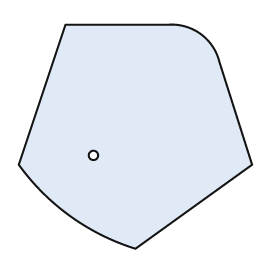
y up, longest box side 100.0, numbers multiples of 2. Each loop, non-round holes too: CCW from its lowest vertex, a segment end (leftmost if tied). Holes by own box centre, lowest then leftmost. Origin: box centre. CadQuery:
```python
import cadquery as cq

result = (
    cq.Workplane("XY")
    .moveTo(0.0, -48.0)
    .lineTo(50.0, -12.0)
    .lineTo(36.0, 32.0)
    .threePointArc((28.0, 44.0), (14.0, 48.0))
    .lineTo(-30.0, 48.0)
    .lineTo(-50.0, -12.0)
    .threePointArc((-28.0, -34.0), (0.0, -48.0))
    .close()
    .moveTo(-18.0, -8.0)
    .circle(2.0)
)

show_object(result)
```